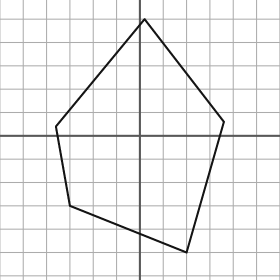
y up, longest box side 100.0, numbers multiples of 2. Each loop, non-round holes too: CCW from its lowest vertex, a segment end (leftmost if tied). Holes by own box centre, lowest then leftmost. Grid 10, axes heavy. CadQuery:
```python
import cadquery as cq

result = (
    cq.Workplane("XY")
    .moveTo(20.0, -50.0)
    .lineTo(36.0, 6.0)
    .lineTo(2.0, 50.0)
    .lineTo(-36.0, 4.0)
    .lineTo(-30.0, -30.0)
    .close()
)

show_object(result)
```